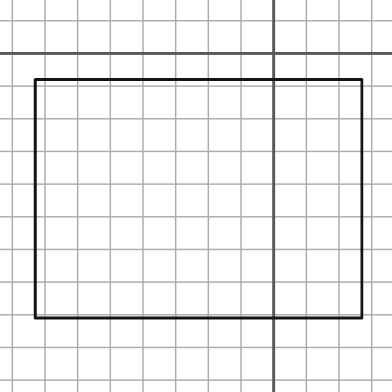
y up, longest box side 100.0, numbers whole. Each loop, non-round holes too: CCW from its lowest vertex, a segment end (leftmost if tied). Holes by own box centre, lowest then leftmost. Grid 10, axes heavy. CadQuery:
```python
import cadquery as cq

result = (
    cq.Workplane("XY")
    .moveTo(-73.0, -81.0)
    .lineTo(27.0, -81.0)
    .lineTo(27.0, -8.0)
    .lineTo(-73.0, -8.0)
    .close()
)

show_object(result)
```